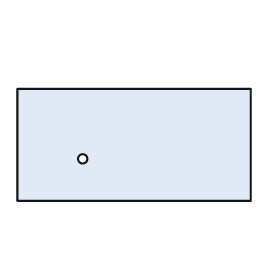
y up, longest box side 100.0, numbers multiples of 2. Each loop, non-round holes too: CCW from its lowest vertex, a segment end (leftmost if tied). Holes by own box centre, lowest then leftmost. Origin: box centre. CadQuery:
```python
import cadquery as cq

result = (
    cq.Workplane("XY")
    .moveTo(-50.0, -24.0)
    .lineTo(50.0, -24.0)
    .lineTo(50.0, 24.0)
    .lineTo(-50.0, 24.0)
    .close()
    .moveTo(-22.0, -6.0)
    .circle(2.0)
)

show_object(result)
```